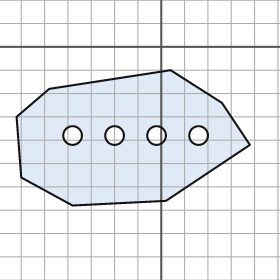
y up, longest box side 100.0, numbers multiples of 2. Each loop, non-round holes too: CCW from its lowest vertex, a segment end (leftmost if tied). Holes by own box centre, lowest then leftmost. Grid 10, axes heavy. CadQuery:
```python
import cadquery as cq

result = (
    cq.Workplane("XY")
    .moveTo(-38.0, -68.0)
    .lineTo(2.0, -66.0)
    .lineTo(38.0, -42.0)
    .lineTo(26.0, -24.0)
    .lineTo(4.0, -10.0)
    .lineTo(-48.0, -18.0)
    .lineTo(-62.0, -30.0)
    .lineTo(-60.0, -56.0)
    .close()
    .moveTo(-38.0, -38.0)
    .circle(4.0)
    .moveTo(-20.0, -38.0)
    .circle(4.0)
    .moveTo(-2.0, -38.0)
    .circle(4.0)
    .moveTo(16.0, -38.0)
    .circle(4.0)
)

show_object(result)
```